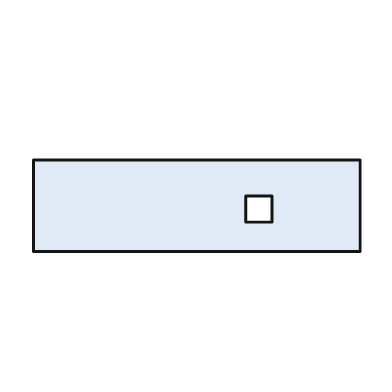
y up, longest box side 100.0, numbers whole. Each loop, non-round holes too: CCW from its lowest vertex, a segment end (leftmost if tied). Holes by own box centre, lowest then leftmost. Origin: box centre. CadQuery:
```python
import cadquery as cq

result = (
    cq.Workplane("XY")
    .moveTo(-50.0, -14.0)
    .lineTo(50.0, -14.0)
    .lineTo(50.0, 14.0)
    .lineTo(-50.0, 14.0)
    .close()
    .moveTo(15.0, -5.0)
    .lineTo(23.0, -5.0)
    .lineTo(23.0, 3.0)
    .lineTo(15.0, 3.0)
    .close()
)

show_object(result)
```